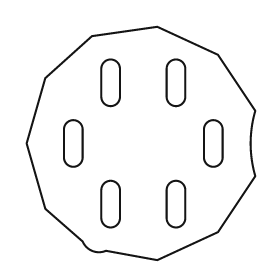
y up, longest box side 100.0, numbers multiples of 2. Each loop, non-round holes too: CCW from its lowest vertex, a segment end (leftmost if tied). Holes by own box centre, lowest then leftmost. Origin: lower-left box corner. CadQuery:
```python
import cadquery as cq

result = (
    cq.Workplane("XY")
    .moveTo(56.0, 0.0)
    .lineTo(82.0, 12.0)
    .lineTo(98.0, 36.0)
    .threePointArc((96.0, 50.0), (98.0, 64.0))
    .lineTo(82.0, 88.0)
    .lineTo(56.0, 100.0)
    .lineTo(28.0, 96.0)
    .lineTo(8.0, 78.0)
    .lineTo(0.0, 50.0)
    .lineTo(8.0, 22.0)
    .lineTo(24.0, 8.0)
    .threePointArc((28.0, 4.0), (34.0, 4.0))
    .close()
    .moveTo(32.0, 18.0)
    .threePointArc((36.0, 14.0), (40.0, 18.0))
    .lineTo(40.0, 30.0)
    .threePointArc((36.0, 34.0), (32.0, 30.0))
    .close()
    .moveTo(60.0, 18.0)
    .threePointArc((64.0, 14.0), (68.0, 18.0))
    .lineTo(68.0, 30.0)
    .threePointArc((64.0, 34.0), (60.0, 30.0))
    .close()
    .moveTo(16.0, 44.0)
    .threePointArc((20.0, 40.0), (24.0, 44.0))
    .lineTo(24.0, 56.0)
    .threePointArc((20.0, 60.0), (16.0, 56.0))
    .close()
    .moveTo(76.0, 44.0)
    .threePointArc((80.0, 40.0), (84.0, 44.0))
    .lineTo(84.0, 56.0)
    .threePointArc((80.0, 60.0), (76.0, 56.0))
    .close()
    .moveTo(32.0, 70.0)
    .threePointArc((36.0, 66.0), (40.0, 70.0))
    .lineTo(40.0, 82.0)
    .threePointArc((36.0, 86.0), (32.0, 82.0))
    .close()
    .moveTo(60.0, 70.0)
    .threePointArc((64.0, 66.0), (68.0, 70.0))
    .lineTo(68.0, 82.0)
    .threePointArc((64.0, 86.0), (60.0, 82.0))
    .close()
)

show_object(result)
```